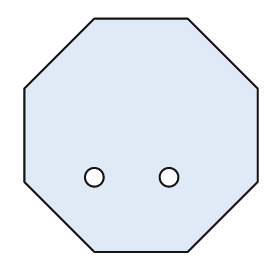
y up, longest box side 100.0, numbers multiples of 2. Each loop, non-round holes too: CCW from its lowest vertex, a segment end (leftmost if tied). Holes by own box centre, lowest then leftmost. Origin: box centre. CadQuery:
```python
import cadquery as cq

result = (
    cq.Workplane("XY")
    .moveTo(-20.0, -50.0)
    .lineTo(20.0, -50.0)
    .lineTo(50.0, -20.0)
    .lineTo(50.0, 20.0)
    .lineTo(20.0, 50.0)
    .lineTo(-20.0, 50.0)
    .lineTo(-50.0, 20.0)
    .lineTo(-50.0, -20.0)
    .close()
    .moveTo(-20.0, -18.0)
    .circle(4.0)
    .moveTo(12.0, -18.0)
    .circle(4.0)
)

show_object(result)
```